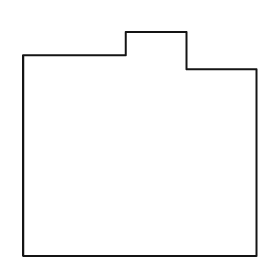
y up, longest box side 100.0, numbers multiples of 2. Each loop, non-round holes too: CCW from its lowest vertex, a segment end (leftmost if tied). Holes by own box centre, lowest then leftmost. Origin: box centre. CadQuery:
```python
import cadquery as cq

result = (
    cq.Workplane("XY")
    .moveTo(-50.0, -48.0)
    .lineTo(50.0, -48.0)
    .lineTo(50.0, 32.0)
    .lineTo(20.0, 32.0)
    .lineTo(20.0, 48.0)
    .lineTo(-6.0, 48.0)
    .lineTo(-6.0, 38.0)
    .lineTo(-50.0, 38.0)
    .close()
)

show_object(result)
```